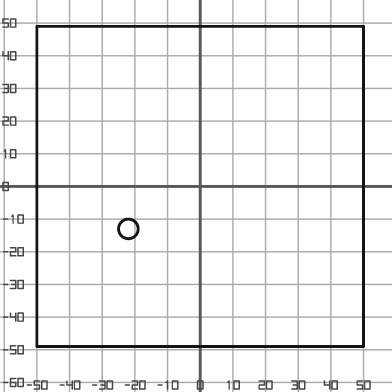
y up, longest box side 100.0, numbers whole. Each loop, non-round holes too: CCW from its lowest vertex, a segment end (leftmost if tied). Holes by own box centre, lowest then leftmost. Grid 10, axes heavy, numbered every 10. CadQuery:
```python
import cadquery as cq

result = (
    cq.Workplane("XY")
    .moveTo(-50.0, -49.0)
    .lineTo(50.0, -49.0)
    .lineTo(50.0, 49.0)
    .lineTo(-50.0, 49.0)
    .close()
    .moveTo(-22.0, -13.0)
    .circle(3.0)
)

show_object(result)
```